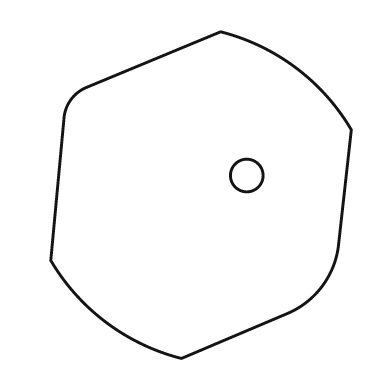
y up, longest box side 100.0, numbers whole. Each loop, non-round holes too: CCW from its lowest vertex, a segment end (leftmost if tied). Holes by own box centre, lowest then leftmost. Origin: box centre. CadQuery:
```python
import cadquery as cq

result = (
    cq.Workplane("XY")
    .moveTo(-6.0, -50.0)
    .lineTo(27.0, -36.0)
    .threePointArc((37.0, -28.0), (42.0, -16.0))
    .lineTo(46.0, 20.0)
    .threePointArc((29.0, 39.0), (6.0, 50.0))
    .lineTo(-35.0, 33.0)
    .threePointArc((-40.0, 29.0), (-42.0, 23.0))
    .lineTo(-46.0, -20.0)
    .threePointArc((-29.0, -39.0), (-6.0, -50.0))
    .close()
    .moveTo(14.0, 6.0)
    .circle(5.0)
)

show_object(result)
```